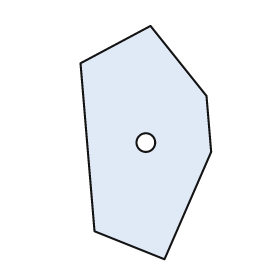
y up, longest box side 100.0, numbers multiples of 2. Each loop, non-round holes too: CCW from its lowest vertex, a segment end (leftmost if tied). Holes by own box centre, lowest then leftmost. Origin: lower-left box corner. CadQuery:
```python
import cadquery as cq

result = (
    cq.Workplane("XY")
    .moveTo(36.0, 0.0)
    .lineTo(56.0, 46.0)
    .lineTo(54.0, 70.0)
    .lineTo(30.0, 100.0)
    .lineTo(0.0, 84.0)
    .lineTo(6.0, 12.0)
    .close()
    .moveTo(28.0, 50.0)
    .circle(4.0)
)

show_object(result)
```